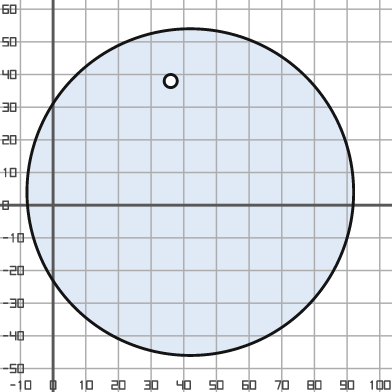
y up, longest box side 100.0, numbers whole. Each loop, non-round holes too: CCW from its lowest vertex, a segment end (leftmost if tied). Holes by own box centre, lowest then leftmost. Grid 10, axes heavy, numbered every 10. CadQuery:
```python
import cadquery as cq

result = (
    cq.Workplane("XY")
    .moveTo(42.0, 4.0)
    .circle(50.0)
    .moveTo(36.0, 38.0)
    .circle(2.0)
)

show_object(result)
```